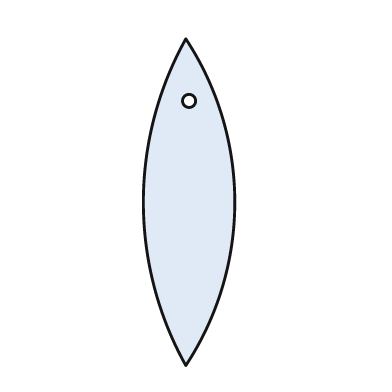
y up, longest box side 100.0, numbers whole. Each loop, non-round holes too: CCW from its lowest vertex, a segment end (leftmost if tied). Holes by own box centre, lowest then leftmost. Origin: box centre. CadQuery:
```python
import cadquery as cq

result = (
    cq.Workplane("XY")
    .moveTo(-1.0, -50.0)
    .threePointArc((14.0, 0.0), (-1.0, 50.0))
    .threePointArc((-14.0, 0.0), (-1.0, -50.0))
    .close()
    .moveTo(0.0, 31.0)
    .circle(2.0)
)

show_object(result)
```